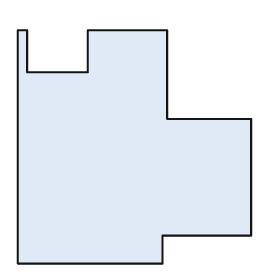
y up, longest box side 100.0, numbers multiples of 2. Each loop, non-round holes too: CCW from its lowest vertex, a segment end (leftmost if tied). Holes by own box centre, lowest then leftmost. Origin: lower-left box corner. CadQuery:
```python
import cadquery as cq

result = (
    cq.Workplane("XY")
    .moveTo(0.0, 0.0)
    .lineTo(62.0, 0.0)
    .lineTo(62.0, 12.0)
    .lineTo(100.0, 12.0)
    .lineTo(100.0, 62.0)
    .lineTo(64.0, 62.0)
    .lineTo(64.0, 100.0)
    .lineTo(30.0, 100.0)
    .lineTo(30.0, 82.0)
    .lineTo(4.0, 82.0)
    .lineTo(4.0, 100.0)
    .lineTo(0.0, 100.0)
    .close()
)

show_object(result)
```